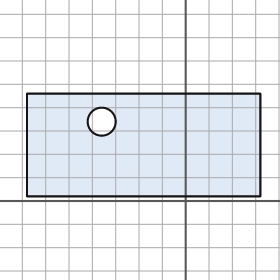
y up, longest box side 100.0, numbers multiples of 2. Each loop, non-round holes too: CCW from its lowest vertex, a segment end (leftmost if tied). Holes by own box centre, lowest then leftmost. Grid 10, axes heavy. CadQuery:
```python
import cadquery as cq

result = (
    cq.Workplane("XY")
    .moveTo(-68.0, 2.0)
    .lineTo(32.0, 2.0)
    .lineTo(32.0, 46.0)
    .lineTo(-68.0, 46.0)
    .close()
    .moveTo(-36.0, 34.0)
    .circle(6.0)
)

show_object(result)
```